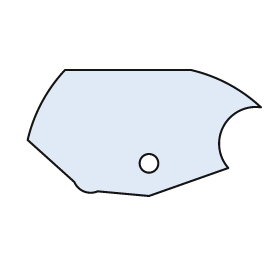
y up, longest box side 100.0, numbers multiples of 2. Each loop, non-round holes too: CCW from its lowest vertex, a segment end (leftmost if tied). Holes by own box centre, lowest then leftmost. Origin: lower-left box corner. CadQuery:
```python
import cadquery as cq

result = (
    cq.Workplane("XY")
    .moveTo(52.0, 0.0)
    .lineTo(86.0, 12.0)
    .threePointArc((84.0, 30.0), (100.0, 38.0))
    .threePointArc((86.0, 48.0), (70.0, 54.0))
    .lineTo(16.0, 54.0)
    .threePointArc((6.0, 40.0), (0.0, 24.0))
    .lineTo(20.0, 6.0)
    .threePointArc((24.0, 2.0), (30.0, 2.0))
    .close()
    .moveTo(52.0, 14.0)
    .circle(4.0)
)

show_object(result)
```